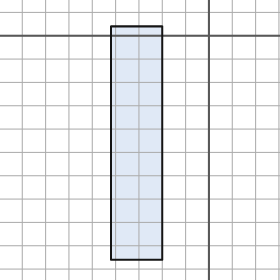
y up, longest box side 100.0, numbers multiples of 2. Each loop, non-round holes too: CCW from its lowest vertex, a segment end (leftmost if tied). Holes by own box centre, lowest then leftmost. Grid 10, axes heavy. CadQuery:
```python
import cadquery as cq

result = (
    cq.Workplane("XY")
    .moveTo(-42.0, -96.0)
    .lineTo(-20.0, -96.0)
    .lineTo(-20.0, 4.0)
    .lineTo(-42.0, 4.0)
    .close()
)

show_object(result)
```